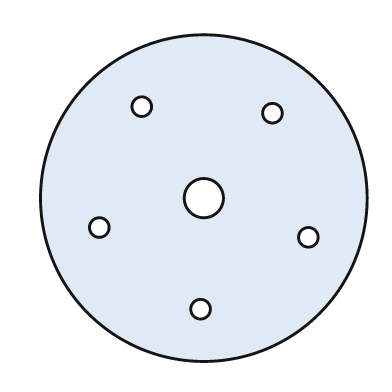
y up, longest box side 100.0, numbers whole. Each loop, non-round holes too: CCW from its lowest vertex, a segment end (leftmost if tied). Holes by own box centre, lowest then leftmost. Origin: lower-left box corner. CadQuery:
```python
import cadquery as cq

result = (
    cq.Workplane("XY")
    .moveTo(50.0, 50.0)
    .circle(50.0)
    .moveTo(49.0, 16.0)
    .circle(3.0)
    .moveTo(82.0, 38.0)
    .circle(3.0)
    .moveTo(18.0, 41.0)
    .circle(3.0)
    .moveTo(50.0, 50.0)
    .circle(6.0)
    .moveTo(71.0, 76.0)
    .circle(3.0)
    .moveTo(31.0, 78.0)
    .circle(3.0)
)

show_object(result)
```